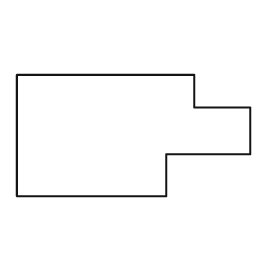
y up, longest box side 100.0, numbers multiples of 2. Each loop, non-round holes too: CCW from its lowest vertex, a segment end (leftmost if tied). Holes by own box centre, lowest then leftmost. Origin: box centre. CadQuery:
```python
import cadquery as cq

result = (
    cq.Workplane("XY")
    .moveTo(-50.0, -26.0)
    .lineTo(14.0, -26.0)
    .lineTo(14.0, -8.0)
    .lineTo(50.0, -8.0)
    .lineTo(50.0, 12.0)
    .lineTo(26.0, 12.0)
    .lineTo(26.0, 26.0)
    .lineTo(-50.0, 26.0)
    .close()
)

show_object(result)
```